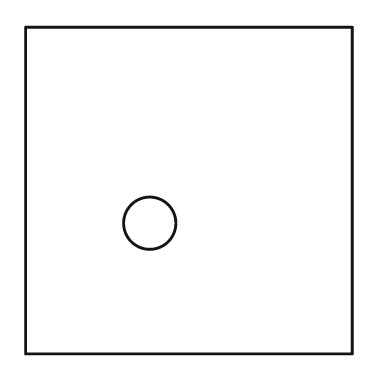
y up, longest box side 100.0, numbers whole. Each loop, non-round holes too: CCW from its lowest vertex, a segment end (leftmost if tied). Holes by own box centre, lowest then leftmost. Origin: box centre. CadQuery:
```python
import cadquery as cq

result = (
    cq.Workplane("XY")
    .moveTo(-50.0, -50.0)
    .lineTo(50.0, -50.0)
    .lineTo(50.0, 50.0)
    .lineTo(-50.0, 50.0)
    .close()
    .moveTo(-12.0, -10.0)
    .circle(8.0)
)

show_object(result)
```